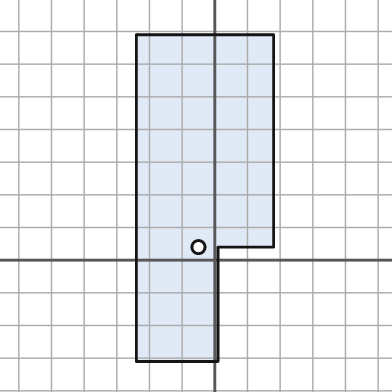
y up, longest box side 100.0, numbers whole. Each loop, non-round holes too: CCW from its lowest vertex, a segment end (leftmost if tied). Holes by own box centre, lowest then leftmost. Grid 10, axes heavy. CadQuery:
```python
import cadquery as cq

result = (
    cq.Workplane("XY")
    .moveTo(-24.0, -31.0)
    .lineTo(1.0, -31.0)
    .lineTo(1.0, 4.0)
    .lineTo(18.0, 4.0)
    .lineTo(18.0, 69.0)
    .lineTo(-24.0, 69.0)
    .close()
    .moveTo(-5.0, 4.0)
    .circle(2.0)
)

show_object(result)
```